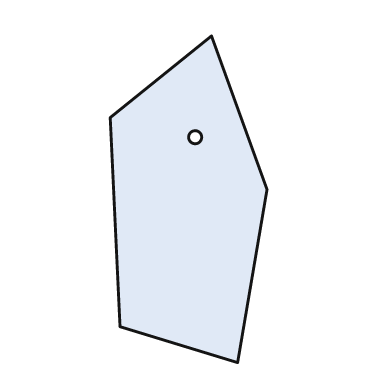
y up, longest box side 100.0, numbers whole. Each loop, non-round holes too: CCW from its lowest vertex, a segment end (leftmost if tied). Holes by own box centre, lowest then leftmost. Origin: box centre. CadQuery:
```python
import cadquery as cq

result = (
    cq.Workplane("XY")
    .moveTo(15.0, -50.0)
    .lineTo(24.0, 3.0)
    .lineTo(7.0, 50.0)
    .lineTo(-24.0, 25.0)
    .lineTo(-21.0, -39.0)
    .close()
    .moveTo(2.0, 19.0)
    .circle(2.0)
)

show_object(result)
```